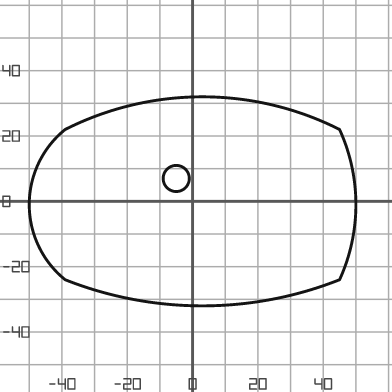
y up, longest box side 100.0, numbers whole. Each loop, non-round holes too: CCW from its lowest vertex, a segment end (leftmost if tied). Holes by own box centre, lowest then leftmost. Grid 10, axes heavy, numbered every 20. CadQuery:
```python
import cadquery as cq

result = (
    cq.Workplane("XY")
    .moveTo(-39.0, -24.0)
    .threePointArc((3.0, -32.0), (45.0, -24.0))
    .threePointArc((50.0, -1.0), (45.0, 22.0))
    .threePointArc((3.0, 32.0), (-39.0, 22.0))
    .threePointArc((-50.0, -1.0), (-39.0, -24.0))
    .close()
    .moveTo(-5.0, 7.0)
    .circle(4.0)
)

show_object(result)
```